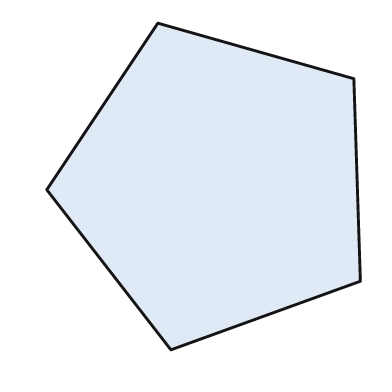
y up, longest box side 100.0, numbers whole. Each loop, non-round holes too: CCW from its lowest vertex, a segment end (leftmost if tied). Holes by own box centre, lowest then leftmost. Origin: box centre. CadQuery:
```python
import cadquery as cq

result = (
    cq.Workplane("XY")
    .moveTo(-10.0, -50.0)
    .lineTo(48.0, -29.0)
    .lineTo(46.0, 33.0)
    .lineTo(-14.0, 50.0)
    .lineTo(-48.0, -1.0)
    .close()
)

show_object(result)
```